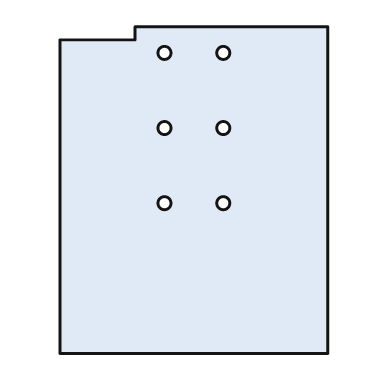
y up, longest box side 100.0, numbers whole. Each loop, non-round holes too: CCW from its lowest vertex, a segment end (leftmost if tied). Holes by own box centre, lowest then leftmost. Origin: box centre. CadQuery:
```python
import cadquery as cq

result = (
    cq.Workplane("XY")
    .moveTo(-41.0, -50.0)
    .lineTo(41.0, -50.0)
    .lineTo(41.0, 50.0)
    .lineTo(-18.0, 50.0)
    .lineTo(-18.0, 46.0)
    .lineTo(-41.0, 46.0)
    .close()
    .moveTo(-9.0, -4.0)
    .circle(2.0)
    .moveTo(9.0, -4.0)
    .circle(2.0)
    .moveTo(-9.0, 19.0)
    .circle(2.0)
    .moveTo(9.0, 19.0)
    .circle(2.0)
    .moveTo(-9.0, 42.0)
    .circle(2.0)
    .moveTo(9.0, 42.0)
    .circle(2.0)
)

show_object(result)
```